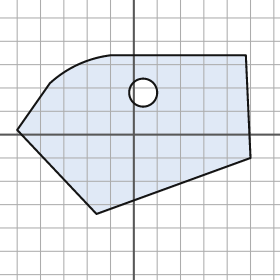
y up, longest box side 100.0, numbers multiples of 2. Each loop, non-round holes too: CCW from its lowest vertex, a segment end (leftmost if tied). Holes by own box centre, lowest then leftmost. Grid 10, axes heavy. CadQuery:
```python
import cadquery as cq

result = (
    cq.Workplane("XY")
    .moveTo(-16.0, -34.0)
    .lineTo(50.0, -10.0)
    .lineTo(48.0, 34.0)
    .lineTo(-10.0, 34.0)
    .threePointArc((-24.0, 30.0), (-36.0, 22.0))
    .lineTo(-50.0, 2.0)
    .close()
    .moveTo(4.0, 18.0)
    .circle(6.0)
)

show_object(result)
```